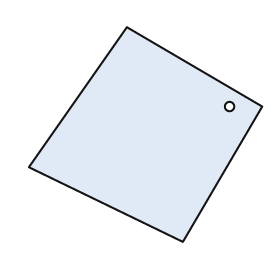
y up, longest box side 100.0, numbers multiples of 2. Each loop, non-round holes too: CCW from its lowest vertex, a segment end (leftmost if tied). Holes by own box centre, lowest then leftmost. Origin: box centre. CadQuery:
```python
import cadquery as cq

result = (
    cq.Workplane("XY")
    .moveTo(16.0, -46.0)
    .lineTo(50.0, 12.0)
    .lineTo(-8.0, 46.0)
    .lineTo(-50.0, -14.0)
    .close()
    .moveTo(36.0, 12.0)
    .circle(2.0)
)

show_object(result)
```